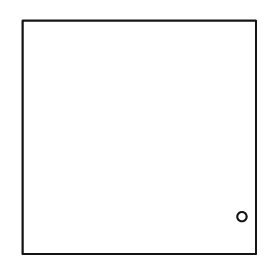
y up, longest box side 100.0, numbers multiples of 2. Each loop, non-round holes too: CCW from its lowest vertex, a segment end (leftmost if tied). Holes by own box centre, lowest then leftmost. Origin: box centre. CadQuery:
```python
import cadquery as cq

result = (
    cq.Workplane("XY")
    .moveTo(-50.0, -50.0)
    .lineTo(50.0, -50.0)
    .lineTo(50.0, 50.0)
    .lineTo(-50.0, 50.0)
    .close()
    .moveTo(44.0, -34.0)
    .circle(2.0)
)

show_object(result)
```